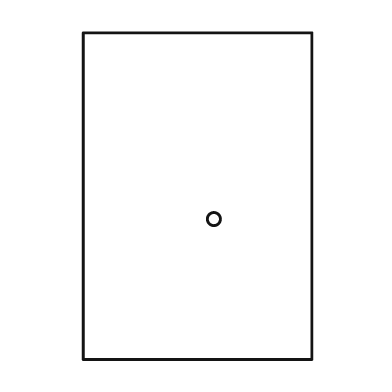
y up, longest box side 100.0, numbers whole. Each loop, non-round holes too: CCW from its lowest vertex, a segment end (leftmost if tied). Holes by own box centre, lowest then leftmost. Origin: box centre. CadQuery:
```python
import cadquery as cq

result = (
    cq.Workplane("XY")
    .moveTo(-35.0, -50.0)
    .lineTo(35.0, -50.0)
    .lineTo(35.0, 50.0)
    .lineTo(-35.0, 50.0)
    .close()
    .moveTo(5.0, -7.0)
    .circle(2.0)
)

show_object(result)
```